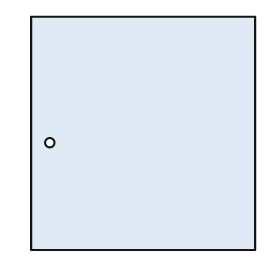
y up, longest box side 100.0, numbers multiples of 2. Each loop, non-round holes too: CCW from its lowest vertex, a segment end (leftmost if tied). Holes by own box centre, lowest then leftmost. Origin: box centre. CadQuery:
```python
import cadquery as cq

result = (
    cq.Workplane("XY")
    .moveTo(-48.0, -50.0)
    .lineTo(48.0, -50.0)
    .lineTo(48.0, 50.0)
    .lineTo(-48.0, 50.0)
    .close()
    .moveTo(-40.0, -4.0)
    .circle(2.0)
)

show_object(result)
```